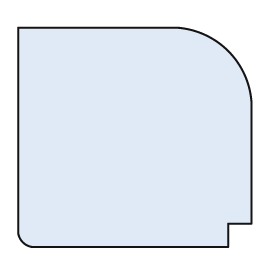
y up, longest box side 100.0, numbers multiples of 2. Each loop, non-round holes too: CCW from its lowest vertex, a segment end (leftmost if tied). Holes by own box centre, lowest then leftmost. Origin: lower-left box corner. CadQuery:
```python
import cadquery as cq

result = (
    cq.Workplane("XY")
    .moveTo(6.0, 0.0)
    .lineTo(90.0, 0.0)
    .lineTo(90.0, 10.0)
    .lineTo(100.0, 10.0)
    .lineTo(100.0, 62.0)
    .threePointArc((90.0, 84.0), (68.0, 94.0))
    .lineTo(0.0, 94.0)
    .lineTo(0.0, 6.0)
    .threePointArc((2.0, 2.0), (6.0, 0.0))
    .close()
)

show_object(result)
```